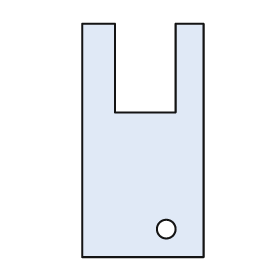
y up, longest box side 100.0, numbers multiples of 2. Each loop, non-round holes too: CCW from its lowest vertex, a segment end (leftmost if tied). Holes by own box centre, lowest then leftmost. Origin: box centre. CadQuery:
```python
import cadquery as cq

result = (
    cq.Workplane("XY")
    .moveTo(-26.0, -50.0)
    .lineTo(26.0, -50.0)
    .lineTo(26.0, 50.0)
    .lineTo(14.0, 50.0)
    .lineTo(14.0, 12.0)
    .lineTo(-12.0, 12.0)
    .lineTo(-12.0, 50.0)
    .lineTo(-26.0, 50.0)
    .close()
    .moveTo(10.0, -38.0)
    .circle(4.0)
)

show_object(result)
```